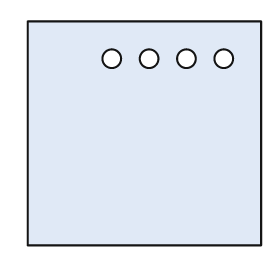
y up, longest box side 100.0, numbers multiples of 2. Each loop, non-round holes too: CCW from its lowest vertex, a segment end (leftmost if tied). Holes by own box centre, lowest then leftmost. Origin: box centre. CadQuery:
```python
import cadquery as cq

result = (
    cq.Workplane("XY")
    .moveTo(-50.0, -48.0)
    .lineTo(50.0, -48.0)
    .lineTo(50.0, 48.0)
    .lineTo(-50.0, 48.0)
    .close()
    .moveTo(-14.0, 32.0)
    .circle(4.0)
    .moveTo(2.0, 32.0)
    .circle(4.0)
    .moveTo(18.0, 32.0)
    .circle(4.0)
    .moveTo(34.0, 32.0)
    .circle(4.0)
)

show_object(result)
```